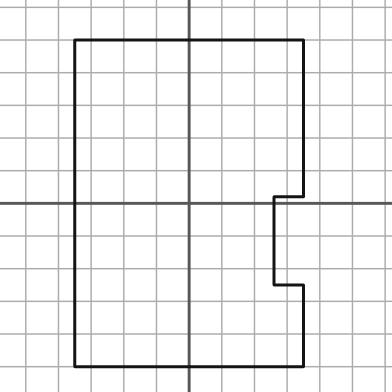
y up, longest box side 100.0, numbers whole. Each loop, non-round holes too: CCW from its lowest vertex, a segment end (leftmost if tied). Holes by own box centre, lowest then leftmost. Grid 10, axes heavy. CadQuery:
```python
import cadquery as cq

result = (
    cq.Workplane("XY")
    .moveTo(-35.0, -50.0)
    .lineTo(35.0, -50.0)
    .lineTo(35.0, -25.0)
    .lineTo(26.0, -25.0)
    .lineTo(26.0, 2.0)
    .lineTo(35.0, 2.0)
    .lineTo(35.0, 50.0)
    .lineTo(-35.0, 50.0)
    .close()
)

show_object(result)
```